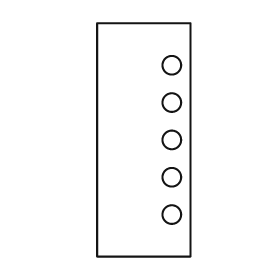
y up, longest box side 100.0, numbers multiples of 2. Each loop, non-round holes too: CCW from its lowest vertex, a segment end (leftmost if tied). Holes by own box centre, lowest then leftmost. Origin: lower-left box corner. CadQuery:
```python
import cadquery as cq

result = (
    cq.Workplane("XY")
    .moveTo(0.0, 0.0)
    .lineTo(40.0, 0.0)
    .lineTo(40.0, 100.0)
    .lineTo(0.0, 100.0)
    .close()
    .moveTo(32.0, 18.0)
    .circle(4.0)
    .moveTo(32.0, 34.0)
    .circle(4.0)
    .moveTo(32.0, 50.0)
    .circle(4.0)
    .moveTo(32.0, 66.0)
    .circle(4.0)
    .moveTo(32.0, 82.0)
    .circle(4.0)
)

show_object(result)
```